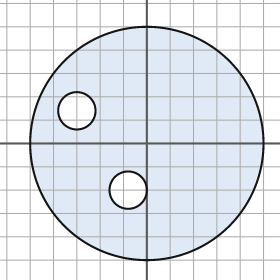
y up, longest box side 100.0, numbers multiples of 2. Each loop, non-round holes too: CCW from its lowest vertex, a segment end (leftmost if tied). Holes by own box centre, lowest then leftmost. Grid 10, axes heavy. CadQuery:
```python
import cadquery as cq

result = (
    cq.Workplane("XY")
    .moveTo(0.0, 0.0)
    .circle(50.0)
    .moveTo(-8.0, -20.0)
    .circle(8.0)
    .moveTo(-30.0, 14.0)
    .circle(8.0)
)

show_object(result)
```